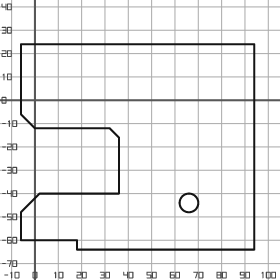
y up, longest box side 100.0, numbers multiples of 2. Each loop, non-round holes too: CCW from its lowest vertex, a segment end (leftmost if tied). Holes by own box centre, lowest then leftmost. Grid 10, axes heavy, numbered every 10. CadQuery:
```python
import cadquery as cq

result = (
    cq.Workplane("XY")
    .moveTo(18.0, -64.0)
    .lineTo(94.0, -64.0)
    .lineTo(94.0, 24.0)
    .lineTo(-6.0, 24.0)
    .lineTo(-6.0, -6.0)
    .lineTo(0.0, -12.0)
    .lineTo(32.0, -12.0)
    .lineTo(36.0, -16.0)
    .lineTo(36.0, -40.0)
    .lineTo(2.0, -40.0)
    .lineTo(-6.0, -48.0)
    .lineTo(-6.0, -60.0)
    .lineTo(18.0, -60.0)
    .close()
    .moveTo(66.0, -44.0)
    .circle(4.0)
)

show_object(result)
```